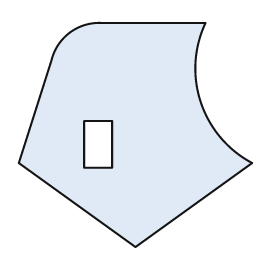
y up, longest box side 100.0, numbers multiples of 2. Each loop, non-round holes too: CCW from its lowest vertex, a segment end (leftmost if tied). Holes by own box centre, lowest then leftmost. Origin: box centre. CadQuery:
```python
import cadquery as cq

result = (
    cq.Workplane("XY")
    .moveTo(0.0, -48.0)
    .lineTo(50.0, -12.0)
    .threePointArc((28.0, 14.0), (30.0, 48.0))
    .lineTo(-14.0, 48.0)
    .threePointArc((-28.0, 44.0), (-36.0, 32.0))
    .lineTo(-50.0, -12.0)
    .close()
    .moveTo(-22.0, -14.0)
    .lineTo(-10.0, -14.0)
    .lineTo(-10.0, 6.0)
    .lineTo(-22.0, 6.0)
    .close()
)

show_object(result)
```